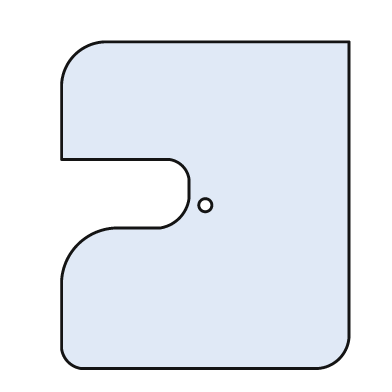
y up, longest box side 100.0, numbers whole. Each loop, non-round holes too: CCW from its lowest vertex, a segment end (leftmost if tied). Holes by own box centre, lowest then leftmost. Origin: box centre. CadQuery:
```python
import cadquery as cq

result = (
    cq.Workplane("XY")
    .moveTo(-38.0, -50.0)
    .lineTo(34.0, -50.0)
    .threePointArc((41.0, -47.0), (44.0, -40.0))
    .lineTo(44.0, 50.0)
    .lineTo(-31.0, 50.0)
    .threePointArc((-40.0, 46.0), (-44.0, 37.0))
    .lineTo(-44.0, 14.0)
    .lineTo(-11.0, 14.0)
    .threePointArc((-7.0, 12.0), (-5.0, 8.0))
    .lineTo(-5.0, 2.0)
    .threePointArc((-8.0, -4.0), (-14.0, -7.0))
    .lineTo(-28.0, -7.0)
    .threePointArc((-39.0, -12.0), (-44.0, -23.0))
    .lineTo(-44.0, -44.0)
    .threePointArc((-42.0, -48.0), (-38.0, -50.0))
    .close()
    .moveTo(0.0, 0.0)
    .circle(2.0)
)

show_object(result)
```